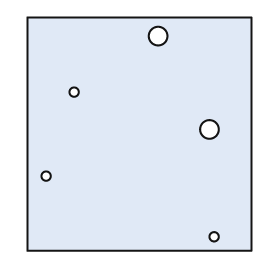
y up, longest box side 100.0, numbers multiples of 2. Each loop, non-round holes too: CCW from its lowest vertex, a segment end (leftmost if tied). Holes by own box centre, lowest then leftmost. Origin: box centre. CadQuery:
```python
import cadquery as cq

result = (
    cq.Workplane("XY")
    .moveTo(-48.0, -50.0)
    .lineTo(48.0, -50.0)
    .lineTo(48.0, 50.0)
    .lineTo(-48.0, 50.0)
    .close()
    .moveTo(32.0, -44.0)
    .circle(2.0)
    .moveTo(-40.0, -18.0)
    .circle(2.0)
    .moveTo(30.0, 2.0)
    .circle(4.0)
    .moveTo(-28.0, 18.0)
    .circle(2.0)
    .moveTo(8.0, 42.0)
    .circle(4.0)
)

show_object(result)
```